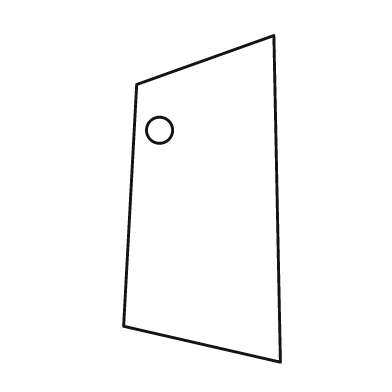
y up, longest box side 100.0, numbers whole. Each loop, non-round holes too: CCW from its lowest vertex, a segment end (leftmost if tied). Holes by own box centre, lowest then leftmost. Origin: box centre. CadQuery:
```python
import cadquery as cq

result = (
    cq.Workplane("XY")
    .moveTo(24.0, -50.0)
    .lineTo(22.0, 50.0)
    .lineTo(-20.0, 35.0)
    .lineTo(-24.0, -39.0)
    .close()
    .moveTo(-13.0, 21.0)
    .circle(4.0)
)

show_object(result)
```